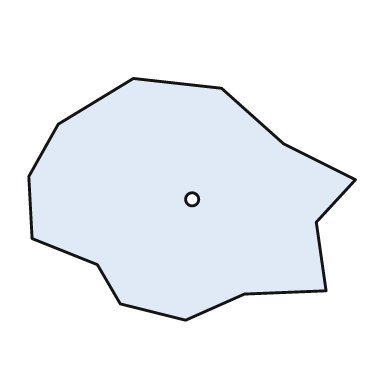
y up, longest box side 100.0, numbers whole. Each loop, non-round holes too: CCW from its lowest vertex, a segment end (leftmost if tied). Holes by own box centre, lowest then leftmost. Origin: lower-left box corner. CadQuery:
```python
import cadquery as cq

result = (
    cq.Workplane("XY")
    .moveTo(48.0, 0.0)
    .lineTo(66.0, 8.0)
    .lineTo(91.0, 9.0)
    .lineTo(88.0, 30.0)
    .lineTo(100.0, 43.0)
    .lineTo(78.0, 54.0)
    .lineTo(59.0, 71.0)
    .lineTo(32.0, 74.0)
    .lineTo(9.0, 60.0)
    .lineTo(0.0, 44.0)
    .lineTo(1.0, 25.0)
    .lineTo(21.0, 17.0)
    .lineTo(28.0, 5.0)
    .close()
    .moveTo(50.0, 37.0)
    .circle(2.0)
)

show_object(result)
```